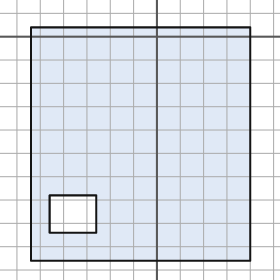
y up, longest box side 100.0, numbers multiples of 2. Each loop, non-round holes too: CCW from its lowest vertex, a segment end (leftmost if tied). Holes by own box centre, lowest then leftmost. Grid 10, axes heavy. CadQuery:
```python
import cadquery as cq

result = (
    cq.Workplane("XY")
    .moveTo(-54.0, -96.0)
    .lineTo(40.0, -96.0)
    .lineTo(40.0, 4.0)
    .lineTo(-54.0, 4.0)
    .close()
    .moveTo(-46.0, -84.0)
    .lineTo(-26.0, -84.0)
    .lineTo(-26.0, -68.0)
    .lineTo(-46.0, -68.0)
    .close()
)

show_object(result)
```